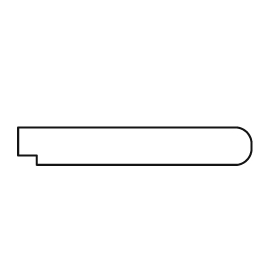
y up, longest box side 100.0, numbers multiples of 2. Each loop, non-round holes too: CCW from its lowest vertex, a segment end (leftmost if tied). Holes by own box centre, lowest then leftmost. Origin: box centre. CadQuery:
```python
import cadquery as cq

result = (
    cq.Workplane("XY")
    .moveTo(-42.0, -8.0)
    .lineTo(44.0, -8.0)
    .threePointArc((48.0, -6.0), (50.0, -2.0))
    .lineTo(50.0, 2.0)
    .threePointArc((48.0, 6.0), (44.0, 8.0))
    .lineTo(-50.0, 8.0)
    .lineTo(-50.0, -4.0)
    .lineTo(-42.0, -4.0)
    .close()
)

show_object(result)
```